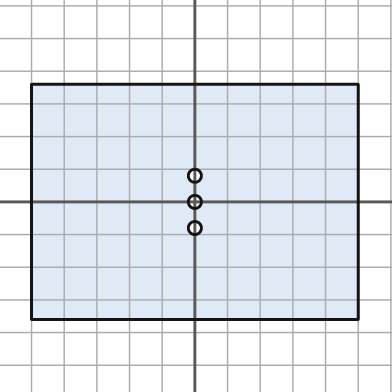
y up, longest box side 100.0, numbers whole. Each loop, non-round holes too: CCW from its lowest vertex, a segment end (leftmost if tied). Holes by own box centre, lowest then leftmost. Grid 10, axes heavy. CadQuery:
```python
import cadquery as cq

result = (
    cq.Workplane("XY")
    .moveTo(-50.0, -36.0)
    .lineTo(50.0, -36.0)
    .lineTo(50.0, 36.0)
    .lineTo(-50.0, 36.0)
    .close()
    .moveTo(0.0, -8.0)
    .circle(2.0)
    .moveTo(0.0, 0.0)
    .circle(2.0)
    .moveTo(0.0, 8.0)
    .circle(2.0)
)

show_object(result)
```